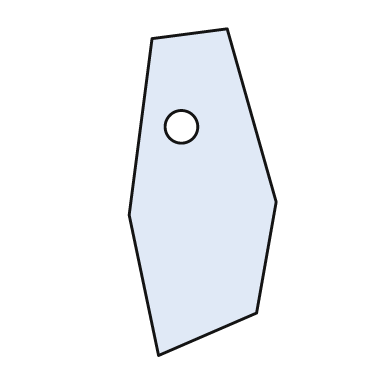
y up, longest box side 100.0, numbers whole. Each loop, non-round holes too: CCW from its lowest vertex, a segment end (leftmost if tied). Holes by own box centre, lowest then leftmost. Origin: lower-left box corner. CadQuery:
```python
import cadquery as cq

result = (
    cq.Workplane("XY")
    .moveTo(9.0, 0.0)
    .lineTo(39.0, 13.0)
    .lineTo(45.0, 47.0)
    .lineTo(30.0, 100.0)
    .lineTo(7.0, 97.0)
    .lineTo(0.0, 43.0)
    .close()
    .moveTo(16.0, 70.0)
    .circle(5.0)
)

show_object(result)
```